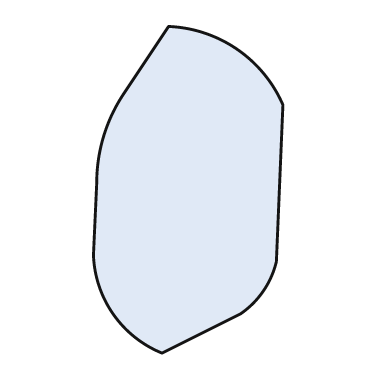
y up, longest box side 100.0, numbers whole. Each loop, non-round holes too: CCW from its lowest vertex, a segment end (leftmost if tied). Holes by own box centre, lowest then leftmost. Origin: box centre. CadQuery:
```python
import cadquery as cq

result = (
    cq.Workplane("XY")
    .moveTo(-8.0, -50.0)
    .lineTo(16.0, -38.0)
    .threePointArc((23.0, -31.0), (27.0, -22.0))
    .lineTo(29.0, 26.0)
    .threePointArc((15.0, 43.0), (-6.0, 50.0))
    .lineTo(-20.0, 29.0)
    .threePointArc((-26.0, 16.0), (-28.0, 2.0))
    .lineTo(-29.0, -20.0)
    .threePointArc((-23.0, -38.0), (-8.0, -50.0))
    .close()
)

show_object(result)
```